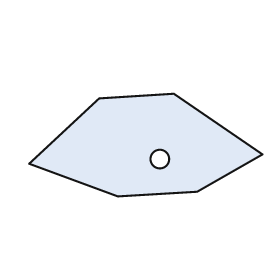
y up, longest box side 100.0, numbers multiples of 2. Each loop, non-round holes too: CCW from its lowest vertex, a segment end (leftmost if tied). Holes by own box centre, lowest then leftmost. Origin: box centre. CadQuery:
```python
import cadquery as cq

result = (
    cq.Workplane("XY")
    .moveTo(-12.0, -22.0)
    .lineTo(22.0, -20.0)
    .lineTo(50.0, -4.0)
    .lineTo(12.0, 22.0)
    .lineTo(-20.0, 20.0)
    .lineTo(-50.0, -8.0)
    .close()
    .moveTo(6.0, -6.0)
    .circle(4.0)
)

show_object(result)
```